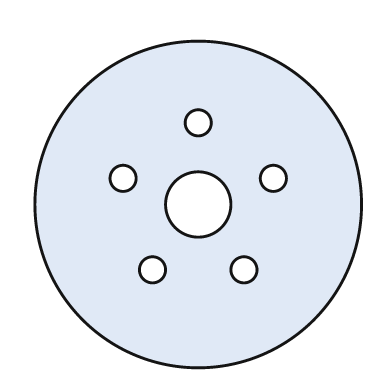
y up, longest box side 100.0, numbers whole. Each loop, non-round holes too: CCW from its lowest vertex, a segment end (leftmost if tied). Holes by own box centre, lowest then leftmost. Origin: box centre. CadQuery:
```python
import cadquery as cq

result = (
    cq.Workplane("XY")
    .moveTo(0.0, 0.0)
    .circle(50.0)
    .moveTo(-14.0, -20.0)
    .circle(4.0)
    .moveTo(14.0, -20.0)
    .circle(4.0)
    .moveTo(0.0, 0.0)
    .circle(10.0)
    .moveTo(-23.0, 8.0)
    .circle(4.0)
    .moveTo(23.0, 8.0)
    .circle(4.0)
    .moveTo(0.0, 25.0)
    .circle(4.0)
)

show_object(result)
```